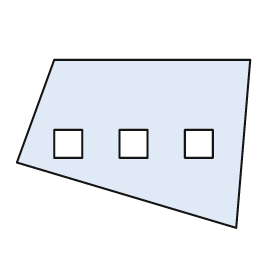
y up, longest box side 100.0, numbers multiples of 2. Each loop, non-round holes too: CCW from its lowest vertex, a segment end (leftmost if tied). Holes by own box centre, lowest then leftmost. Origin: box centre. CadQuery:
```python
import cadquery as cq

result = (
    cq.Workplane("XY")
    .moveTo(44.0, -36.0)
    .lineTo(50.0, 36.0)
    .lineTo(-34.0, 36.0)
    .lineTo(-50.0, -8.0)
    .close()
    .moveTo(-34.0, -6.0)
    .lineTo(-22.0, -6.0)
    .lineTo(-22.0, 6.0)
    .lineTo(-34.0, 6.0)
    .close()
    .moveTo(-6.0, -6.0)
    .lineTo(6.0, -6.0)
    .lineTo(6.0, 6.0)
    .lineTo(-6.0, 6.0)
    .close()
    .moveTo(22.0, -6.0)
    .lineTo(34.0, -6.0)
    .lineTo(34.0, 6.0)
    .lineTo(22.0, 6.0)
    .close()
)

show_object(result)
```